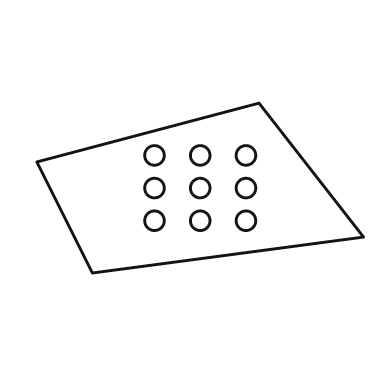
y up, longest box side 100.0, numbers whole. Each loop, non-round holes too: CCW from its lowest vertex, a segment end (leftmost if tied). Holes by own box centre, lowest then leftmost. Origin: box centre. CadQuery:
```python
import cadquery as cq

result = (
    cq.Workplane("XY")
    .moveTo(-33.0, -26.0)
    .lineTo(50.0, -15.0)
    .lineTo(18.0, 26.0)
    .lineTo(-50.0, 8.0)
    .close()
    .moveTo(-14.0, -10.0)
    .circle(3.0)
    .moveTo(0.0, -10.0)
    .circle(3.0)
    .moveTo(14.0, -10.0)
    .circle(3.0)
    .moveTo(-14.0, 0.0)
    .circle(3.0)
    .moveTo(0.0, 0.0)
    .circle(3.0)
    .moveTo(14.0, 0.0)
    .circle(3.0)
    .moveTo(-14.0, 10.0)
    .circle(3.0)
    .moveTo(0.0, 10.0)
    .circle(3.0)
    .moveTo(14.0, 10.0)
    .circle(3.0)
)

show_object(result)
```